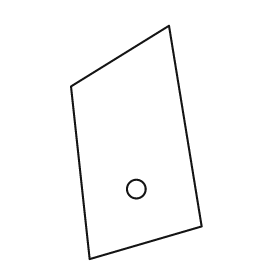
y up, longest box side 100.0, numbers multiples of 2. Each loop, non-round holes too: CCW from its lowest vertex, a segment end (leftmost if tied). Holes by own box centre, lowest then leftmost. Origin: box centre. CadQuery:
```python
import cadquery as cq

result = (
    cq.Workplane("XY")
    .moveTo(-20.0, -50.0)
    .lineTo(28.0, -36.0)
    .lineTo(14.0, 50.0)
    .lineTo(-28.0, 24.0)
    .close()
    .moveTo(0.0, -20.0)
    .circle(4.0)
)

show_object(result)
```